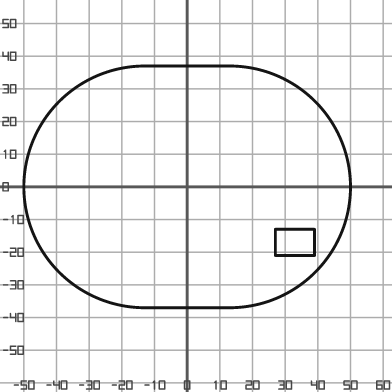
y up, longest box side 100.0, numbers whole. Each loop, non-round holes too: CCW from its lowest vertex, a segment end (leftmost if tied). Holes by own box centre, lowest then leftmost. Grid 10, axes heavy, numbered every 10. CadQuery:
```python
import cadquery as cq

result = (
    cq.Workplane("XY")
    .moveTo(-13.0, -37.0)
    .lineTo(13.0, -37.0)
    .threePointArc((50.0, 0.0), (13.0, 37.0))
    .lineTo(-13.0, 37.0)
    .threePointArc((-50.0, 0.0), (-13.0, -37.0))
    .close()
    .moveTo(27.0, -21.0)
    .lineTo(39.0, -21.0)
    .lineTo(39.0, -13.0)
    .lineTo(27.0, -13.0)
    .close()
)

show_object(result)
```